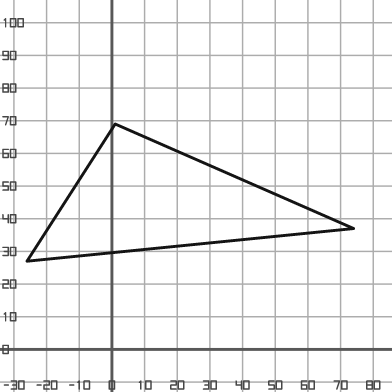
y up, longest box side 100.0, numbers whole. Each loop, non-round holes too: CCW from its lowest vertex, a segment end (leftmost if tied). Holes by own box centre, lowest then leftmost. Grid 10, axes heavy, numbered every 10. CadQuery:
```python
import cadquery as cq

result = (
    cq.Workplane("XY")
    .moveTo(-26.0, 27.0)
    .lineTo(74.0, 37.0)
    .lineTo(1.0, 69.0)
    .close()
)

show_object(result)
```